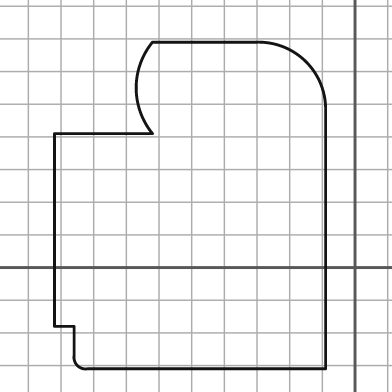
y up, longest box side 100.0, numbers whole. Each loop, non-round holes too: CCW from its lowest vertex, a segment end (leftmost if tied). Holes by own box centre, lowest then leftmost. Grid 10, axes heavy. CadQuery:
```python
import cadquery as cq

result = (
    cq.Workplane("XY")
    .moveTo(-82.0, -31.0)
    .lineTo(-9.0, -31.0)
    .lineTo(-9.0, 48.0)
    .threePointArc((-15.0, 63.0), (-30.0, 69.0))
    .lineTo(-62.0, 69.0)
    .threePointArc((-67.0, 55.0), (-62.0, 41.0))
    .lineTo(-92.0, 41.0)
    .lineTo(-92.0, -18.0)
    .lineTo(-86.0, -18.0)
    .lineTo(-86.0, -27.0)
    .threePointArc((-85.0, -30.0), (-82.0, -31.0))
    .close()
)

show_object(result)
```